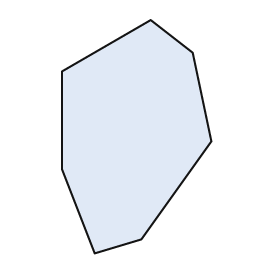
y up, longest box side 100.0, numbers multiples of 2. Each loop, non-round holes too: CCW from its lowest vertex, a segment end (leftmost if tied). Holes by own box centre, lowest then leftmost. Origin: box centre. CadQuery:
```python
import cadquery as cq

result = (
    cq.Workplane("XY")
    .moveTo(-18.0, -50.0)
    .lineTo(2.0, -44.0)
    .lineTo(32.0, -2.0)
    .lineTo(24.0, 36.0)
    .lineTo(6.0, 50.0)
    .lineTo(-32.0, 28.0)
    .lineTo(-32.0, -14.0)
    .close()
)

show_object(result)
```